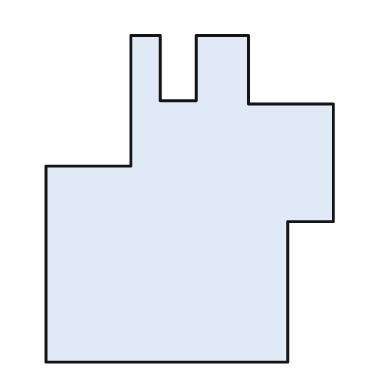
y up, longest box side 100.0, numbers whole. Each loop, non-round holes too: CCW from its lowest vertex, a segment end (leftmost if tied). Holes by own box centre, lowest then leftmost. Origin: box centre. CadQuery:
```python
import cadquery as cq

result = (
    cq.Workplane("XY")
    .moveTo(-44.0, -50.0)
    .lineTo(30.0, -50.0)
    .lineTo(30.0, -7.0)
    .lineTo(44.0, -7.0)
    .lineTo(44.0, 29.0)
    .lineTo(18.0, 29.0)
    .lineTo(18.0, 50.0)
    .lineTo(2.0, 50.0)
    .lineTo(2.0, 30.0)
    .lineTo(-9.0, 30.0)
    .lineTo(-9.0, 50.0)
    .lineTo(-18.0, 50.0)
    .lineTo(-18.0, 10.0)
    .lineTo(-44.0, 10.0)
    .close()
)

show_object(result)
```